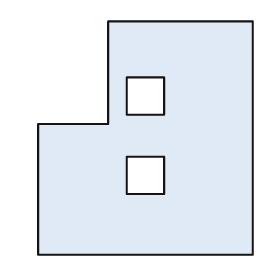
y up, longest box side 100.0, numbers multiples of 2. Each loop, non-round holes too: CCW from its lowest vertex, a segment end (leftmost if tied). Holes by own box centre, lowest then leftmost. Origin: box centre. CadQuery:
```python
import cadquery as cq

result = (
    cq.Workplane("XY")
    .moveTo(-46.0, -50.0)
    .lineTo(46.0, -50.0)
    .lineTo(46.0, 50.0)
    .lineTo(-16.0, 50.0)
    .lineTo(-16.0, 6.0)
    .lineTo(-46.0, 6.0)
    .close()
    .moveTo(-8.0, -24.0)
    .lineTo(8.0, -24.0)
    .lineTo(8.0, -8.0)
    .lineTo(-8.0, -8.0)
    .close()
    .moveTo(-8.0, 10.0)
    .lineTo(8.0, 10.0)
    .lineTo(8.0, 26.0)
    .lineTo(-8.0, 26.0)
    .close()
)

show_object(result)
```